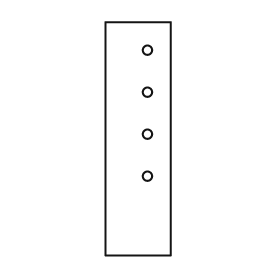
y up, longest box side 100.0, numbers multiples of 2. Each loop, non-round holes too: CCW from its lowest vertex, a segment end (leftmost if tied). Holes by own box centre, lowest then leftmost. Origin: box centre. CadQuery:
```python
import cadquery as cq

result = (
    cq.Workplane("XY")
    .moveTo(-14.0, -50.0)
    .lineTo(14.0, -50.0)
    .lineTo(14.0, 50.0)
    .lineTo(-14.0, 50.0)
    .close()
    .moveTo(4.0, -16.0)
    .circle(2.0)
    .moveTo(4.0, 2.0)
    .circle(2.0)
    .moveTo(4.0, 20.0)
    .circle(2.0)
    .moveTo(4.0, 38.0)
    .circle(2.0)
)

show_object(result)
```